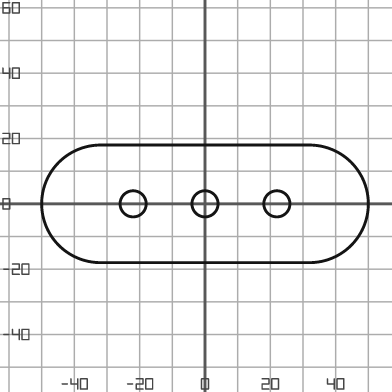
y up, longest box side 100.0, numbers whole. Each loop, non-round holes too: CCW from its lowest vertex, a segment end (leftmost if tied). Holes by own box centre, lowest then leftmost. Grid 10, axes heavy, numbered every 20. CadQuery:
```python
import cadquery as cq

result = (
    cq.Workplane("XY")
    .moveTo(-32.0, -18.0)
    .lineTo(32.0, -18.0)
    .threePointArc((50.0, 0.0), (32.0, 18.0))
    .lineTo(-32.0, 18.0)
    .threePointArc((-50.0, 0.0), (-32.0, -18.0))
    .close()
    .moveTo(-22.0, 0.0)
    .circle(4.0)
    .moveTo(0.0, 0.0)
    .circle(4.0)
    .moveTo(22.0, 0.0)
    .circle(4.0)
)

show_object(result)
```